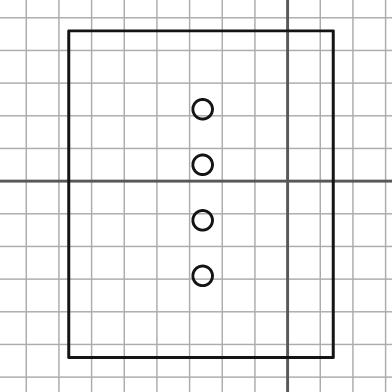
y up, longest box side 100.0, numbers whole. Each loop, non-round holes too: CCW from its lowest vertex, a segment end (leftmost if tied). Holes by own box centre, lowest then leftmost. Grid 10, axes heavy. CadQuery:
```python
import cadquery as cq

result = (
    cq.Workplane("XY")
    .moveTo(-67.0, -54.0)
    .lineTo(14.0, -54.0)
    .lineTo(14.0, 46.0)
    .lineTo(-67.0, 46.0)
    .close()
    .moveTo(-26.0, -29.0)
    .circle(3.0)
    .moveTo(-26.0, -12.0)
    .circle(3.0)
    .moveTo(-26.0, 5.0)
    .circle(3.0)
    .moveTo(-26.0, 22.0)
    .circle(3.0)
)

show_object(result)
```